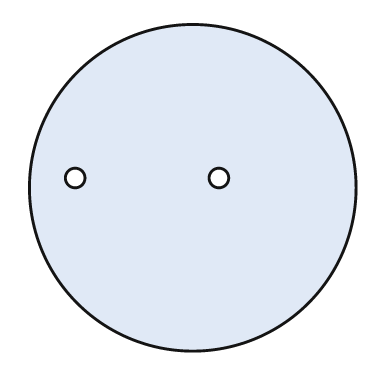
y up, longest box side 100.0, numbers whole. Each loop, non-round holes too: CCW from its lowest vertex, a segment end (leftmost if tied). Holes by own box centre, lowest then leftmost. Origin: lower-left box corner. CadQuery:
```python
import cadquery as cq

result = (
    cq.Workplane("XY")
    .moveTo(50.0, 50.0)
    .circle(50.0)
    .moveTo(14.0, 53.0)
    .circle(3.0)
    .moveTo(58.0, 53.0)
    .circle(3.0)
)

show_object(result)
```